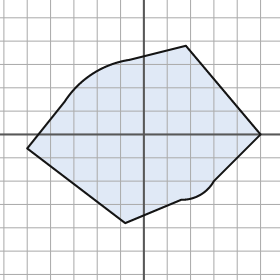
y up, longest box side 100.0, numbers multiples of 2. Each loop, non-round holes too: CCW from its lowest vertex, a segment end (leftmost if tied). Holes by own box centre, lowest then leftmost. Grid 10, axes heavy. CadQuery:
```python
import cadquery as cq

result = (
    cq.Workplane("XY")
    .moveTo(-8.0, -38.0)
    .lineTo(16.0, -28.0)
    .threePointArc((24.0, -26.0), (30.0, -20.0))
    .lineTo(50.0, 0.0)
    .lineTo(18.0, 38.0)
    .lineTo(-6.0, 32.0)
    .threePointArc((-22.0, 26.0), (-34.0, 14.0))
    .lineTo(-50.0, -6.0)
    .close()
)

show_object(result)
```